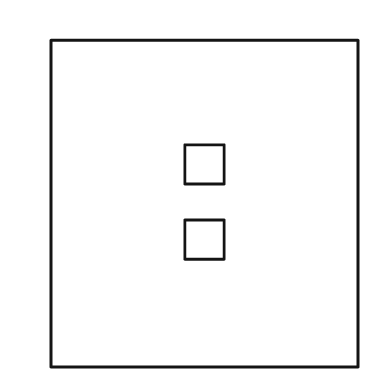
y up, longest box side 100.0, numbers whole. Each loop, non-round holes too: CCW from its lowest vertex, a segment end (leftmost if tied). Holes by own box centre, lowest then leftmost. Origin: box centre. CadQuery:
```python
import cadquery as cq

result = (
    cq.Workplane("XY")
    .moveTo(-47.0, -50.0)
    .lineTo(47.0, -50.0)
    .lineTo(47.0, 50.0)
    .lineTo(-47.0, 50.0)
    .close()
    .moveTo(-6.0, -17.0)
    .lineTo(6.0, -17.0)
    .lineTo(6.0, -5.0)
    .lineTo(-6.0, -5.0)
    .close()
    .moveTo(-6.0, 6.0)
    .lineTo(6.0, 6.0)
    .lineTo(6.0, 18.0)
    .lineTo(-6.0, 18.0)
    .close()
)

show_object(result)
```